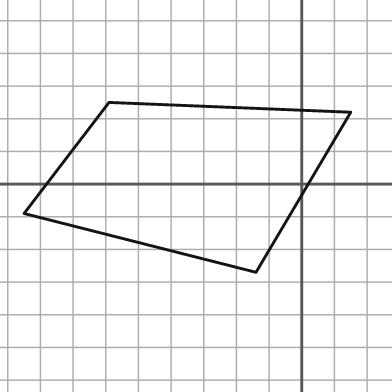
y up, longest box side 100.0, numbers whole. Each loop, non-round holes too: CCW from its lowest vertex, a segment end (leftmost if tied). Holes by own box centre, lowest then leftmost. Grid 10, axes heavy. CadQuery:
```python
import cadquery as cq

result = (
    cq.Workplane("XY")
    .moveTo(-14.0, -27.0)
    .lineTo(15.0, 22.0)
    .lineTo(-59.0, 25.0)
    .lineTo(-85.0, -9.0)
    .close()
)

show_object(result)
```